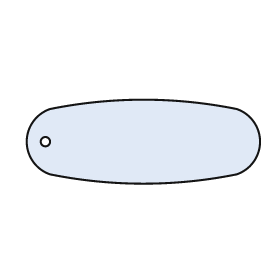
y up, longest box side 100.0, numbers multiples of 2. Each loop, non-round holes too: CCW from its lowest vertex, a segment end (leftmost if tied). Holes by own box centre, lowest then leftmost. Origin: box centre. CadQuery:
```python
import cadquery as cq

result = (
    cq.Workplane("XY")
    .moveTo(-40.0, -14.0)
    .threePointArc((0.0, -18.0), (40.0, -14.0))
    .threePointArc((50.0, 0.0), (40.0, 14.0))
    .threePointArc((0.0, 18.0), (-40.0, 14.0))
    .threePointArc((-50.0, 0.0), (-40.0, -14.0))
    .close()
    .moveTo(-42.0, 0.0)
    .circle(2.0)
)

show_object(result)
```